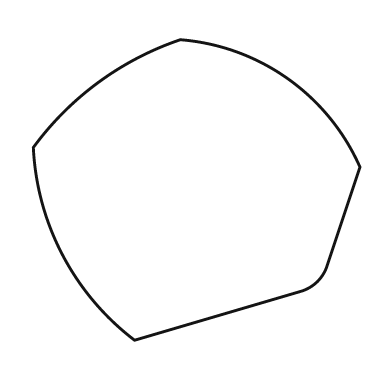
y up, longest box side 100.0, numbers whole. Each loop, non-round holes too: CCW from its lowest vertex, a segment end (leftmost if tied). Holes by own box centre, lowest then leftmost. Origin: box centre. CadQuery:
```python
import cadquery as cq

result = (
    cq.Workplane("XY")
    .moveTo(-19.0, -46.0)
    .lineTo(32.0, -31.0)
    .threePointArc((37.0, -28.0), (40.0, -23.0))
    .lineTo(50.0, 7.0)
    .threePointArc((28.0, 34.0), (-5.0, 46.0))
    .threePointArc((-30.0, 33.0), (-50.0, 13.0))
    .threePointArc((-41.0, -20.0), (-19.0, -46.0))
    .close()
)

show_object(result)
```